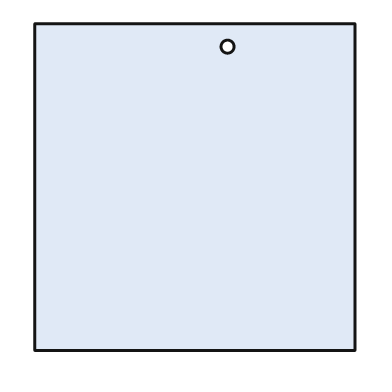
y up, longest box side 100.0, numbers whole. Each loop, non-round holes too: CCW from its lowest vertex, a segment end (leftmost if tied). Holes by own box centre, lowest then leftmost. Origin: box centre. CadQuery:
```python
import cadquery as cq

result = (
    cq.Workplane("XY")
    .moveTo(-49.0, -50.0)
    .lineTo(49.0, -50.0)
    .lineTo(49.0, 50.0)
    .lineTo(-49.0, 50.0)
    .close()
    .moveTo(10.0, 43.0)
    .circle(2.0)
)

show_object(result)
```